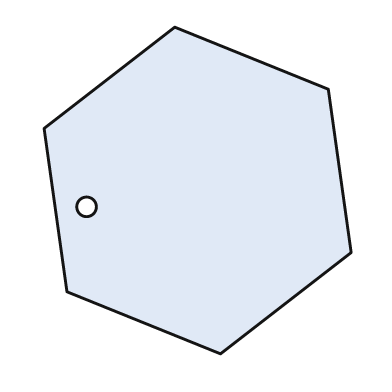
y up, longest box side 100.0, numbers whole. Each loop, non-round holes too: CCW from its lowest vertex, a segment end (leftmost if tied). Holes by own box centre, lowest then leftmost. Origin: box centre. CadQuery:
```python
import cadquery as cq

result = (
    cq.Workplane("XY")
    .moveTo(7.0, -50.0)
    .lineTo(47.0, -19.0)
    .lineTo(40.0, 31.0)
    .lineTo(-7.0, 50.0)
    .lineTo(-47.0, 19.0)
    .lineTo(-40.0, -31.0)
    .close()
    .moveTo(-34.0, -5.0)
    .circle(3.0)
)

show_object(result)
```